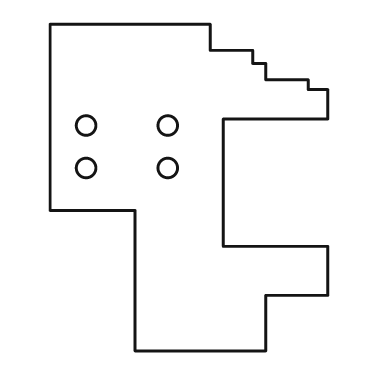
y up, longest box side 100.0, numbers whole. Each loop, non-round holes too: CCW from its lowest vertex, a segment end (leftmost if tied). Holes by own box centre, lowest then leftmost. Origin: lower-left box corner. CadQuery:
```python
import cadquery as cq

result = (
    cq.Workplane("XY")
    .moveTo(26.0, 0.0)
    .lineTo(66.0, 0.0)
    .lineTo(66.0, 17.0)
    .lineTo(85.0, 17.0)
    .lineTo(85.0, 32.0)
    .lineTo(53.0, 32.0)
    .lineTo(53.0, 71.0)
    .lineTo(85.0, 71.0)
    .lineTo(85.0, 80.0)
    .lineTo(79.0, 80.0)
    .lineTo(79.0, 83.0)
    .lineTo(66.0, 83.0)
    .lineTo(66.0, 88.0)
    .lineTo(62.0, 88.0)
    .lineTo(62.0, 92.0)
    .lineTo(49.0, 92.0)
    .lineTo(49.0, 100.0)
    .lineTo(0.0, 100.0)
    .lineTo(0.0, 43.0)
    .lineTo(26.0, 43.0)
    .close()
    .moveTo(11.0, 56.0)
    .circle(3.0)
    .moveTo(36.0, 56.0)
    .circle(3.0)
    .moveTo(11.0, 69.0)
    .circle(3.0)
    .moveTo(36.0, 69.0)
    .circle(3.0)
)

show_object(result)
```